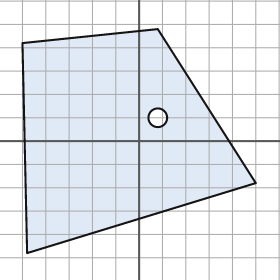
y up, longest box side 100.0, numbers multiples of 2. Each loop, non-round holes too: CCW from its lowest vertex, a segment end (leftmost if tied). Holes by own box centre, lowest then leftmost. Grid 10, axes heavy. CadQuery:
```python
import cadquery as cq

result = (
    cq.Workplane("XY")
    .moveTo(-48.0, -48.0)
    .lineTo(50.0, -18.0)
    .lineTo(8.0, 48.0)
    .lineTo(-50.0, 42.0)
    .close()
    .moveTo(8.0, 10.0)
    .circle(4.0)
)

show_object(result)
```